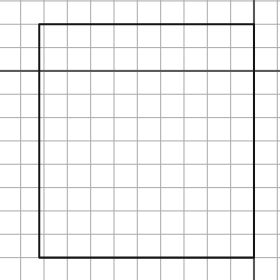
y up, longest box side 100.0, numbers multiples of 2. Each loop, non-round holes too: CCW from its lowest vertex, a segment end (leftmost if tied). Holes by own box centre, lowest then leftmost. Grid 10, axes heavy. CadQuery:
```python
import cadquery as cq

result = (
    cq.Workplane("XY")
    .moveTo(-92.0, -80.0)
    .lineTo(0.0, -80.0)
    .lineTo(0.0, 20.0)
    .lineTo(-92.0, 20.0)
    .close()
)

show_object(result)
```